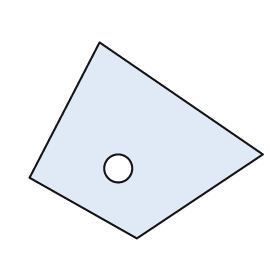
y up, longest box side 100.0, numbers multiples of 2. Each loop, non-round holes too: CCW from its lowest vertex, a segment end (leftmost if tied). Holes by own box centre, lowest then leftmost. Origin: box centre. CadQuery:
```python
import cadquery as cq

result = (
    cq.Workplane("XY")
    .moveTo(-4.0, -42.0)
    .lineTo(50.0, -6.0)
    .lineTo(-20.0, 42.0)
    .lineTo(-50.0, -16.0)
    .close()
    .moveTo(-12.0, -12.0)
    .circle(6.0)
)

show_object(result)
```